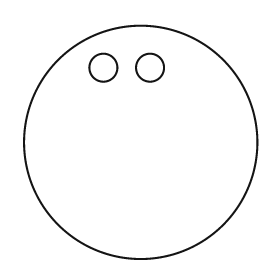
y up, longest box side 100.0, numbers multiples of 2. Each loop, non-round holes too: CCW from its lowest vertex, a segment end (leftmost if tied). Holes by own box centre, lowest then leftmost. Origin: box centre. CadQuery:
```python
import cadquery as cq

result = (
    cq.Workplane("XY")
    .moveTo(0.0, 0.0)
    .circle(50.0)
    .moveTo(-16.0, 32.0)
    .circle(6.0)
    .moveTo(4.0, 32.0)
    .circle(6.0)
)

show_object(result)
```